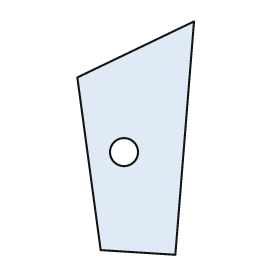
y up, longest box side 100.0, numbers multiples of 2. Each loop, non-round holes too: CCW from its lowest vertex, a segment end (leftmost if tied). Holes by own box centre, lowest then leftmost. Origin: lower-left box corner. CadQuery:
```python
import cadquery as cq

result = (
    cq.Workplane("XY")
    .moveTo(42.0, 0.0)
    .lineTo(50.0, 100.0)
    .lineTo(0.0, 76.0)
    .lineTo(10.0, 2.0)
    .close()
    .moveTo(20.0, 44.0)
    .circle(6.0)
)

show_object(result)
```